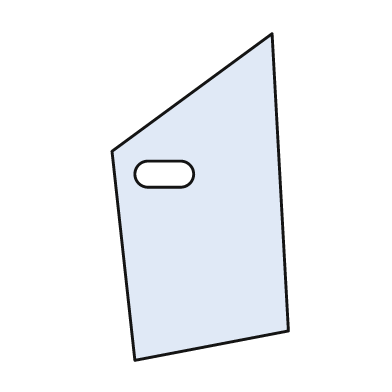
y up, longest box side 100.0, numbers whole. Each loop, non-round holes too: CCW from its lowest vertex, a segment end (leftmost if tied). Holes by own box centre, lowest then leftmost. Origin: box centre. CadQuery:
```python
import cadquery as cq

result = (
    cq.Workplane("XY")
    .moveTo(-20.0, -50.0)
    .lineTo(27.0, -41.0)
    .lineTo(22.0, 50.0)
    .lineTo(-27.0, 14.0)
    .close()
    .moveTo(-16.0, 3.0)
    .lineTo(-6.0, 3.0)
    .threePointArc((-2.0, 7.0), (-6.0, 11.0))
    .lineTo(-16.0, 11.0)
    .threePointArc((-20.0, 7.0), (-16.0, 3.0))
    .close()
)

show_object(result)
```